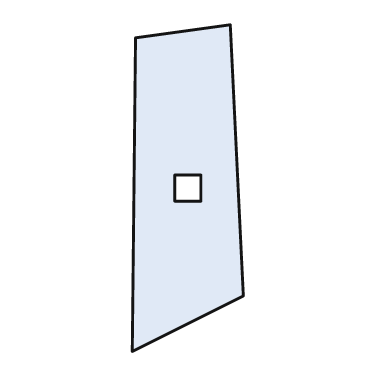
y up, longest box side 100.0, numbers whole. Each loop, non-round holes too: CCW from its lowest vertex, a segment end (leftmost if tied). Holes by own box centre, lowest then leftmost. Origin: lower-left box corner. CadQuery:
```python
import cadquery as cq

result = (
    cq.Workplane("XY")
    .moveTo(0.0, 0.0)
    .lineTo(34.0, 17.0)
    .lineTo(30.0, 100.0)
    .lineTo(1.0, 96.0)
    .close()
    .moveTo(13.0, 46.0)
    .lineTo(21.0, 46.0)
    .lineTo(21.0, 54.0)
    .lineTo(13.0, 54.0)
    .close()
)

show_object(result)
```